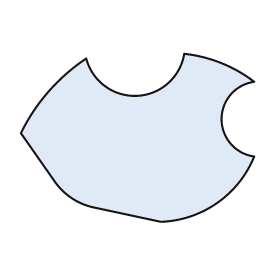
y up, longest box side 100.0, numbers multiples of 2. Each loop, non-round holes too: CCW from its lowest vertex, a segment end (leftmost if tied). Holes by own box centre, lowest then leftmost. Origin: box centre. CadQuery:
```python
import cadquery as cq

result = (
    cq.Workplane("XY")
    .moveTo(10.0, -36.0)
    .threePointArc((34.0, -28.0), (50.0, -8.0))
    .threePointArc((36.0, 8.0), (50.0, 24.0))
    .threePointArc((36.0, 32.0), (20.0, 36.0))
    .threePointArc((0.0, 18.0), (-22.0, 34.0))
    .threePointArc((-38.0, 20.0), (-50.0, 2.0))
    .lineTo(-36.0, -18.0)
    .threePointArc((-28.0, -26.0), (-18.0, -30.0))
    .close()
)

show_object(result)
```